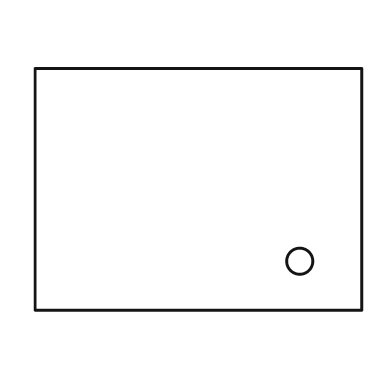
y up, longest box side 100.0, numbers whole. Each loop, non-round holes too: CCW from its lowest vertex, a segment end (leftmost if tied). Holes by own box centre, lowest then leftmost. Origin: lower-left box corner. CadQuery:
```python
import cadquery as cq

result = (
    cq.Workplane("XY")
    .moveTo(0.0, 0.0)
    .lineTo(100.0, 0.0)
    .lineTo(100.0, 74.0)
    .lineTo(0.0, 74.0)
    .close()
    .moveTo(81.0, 15.0)
    .circle(4.0)
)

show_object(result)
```